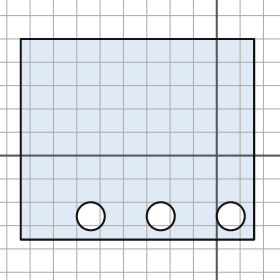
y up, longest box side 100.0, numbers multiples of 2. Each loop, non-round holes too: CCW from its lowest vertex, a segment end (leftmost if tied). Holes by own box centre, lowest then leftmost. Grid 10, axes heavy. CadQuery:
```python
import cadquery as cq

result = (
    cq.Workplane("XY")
    .moveTo(-84.0, -36.0)
    .lineTo(16.0, -36.0)
    .lineTo(16.0, 50.0)
    .lineTo(-84.0, 50.0)
    .close()
    .moveTo(-54.0, -26.0)
    .circle(6.0)
    .moveTo(-24.0, -26.0)
    .circle(6.0)
    .moveTo(6.0, -26.0)
    .circle(6.0)
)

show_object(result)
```